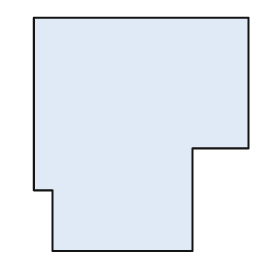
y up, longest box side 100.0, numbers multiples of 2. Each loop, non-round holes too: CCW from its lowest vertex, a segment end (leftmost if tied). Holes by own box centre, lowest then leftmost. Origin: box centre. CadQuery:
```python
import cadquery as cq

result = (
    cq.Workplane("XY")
    .moveTo(-38.0, -50.0)
    .lineTo(22.0, -50.0)
    .lineTo(22.0, -6.0)
    .lineTo(46.0, -6.0)
    .lineTo(46.0, 50.0)
    .lineTo(-46.0, 50.0)
    .lineTo(-46.0, -24.0)
    .lineTo(-38.0, -24.0)
    .close()
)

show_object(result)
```